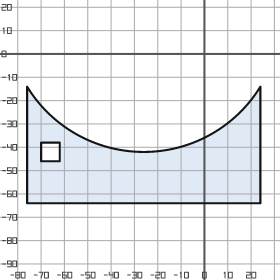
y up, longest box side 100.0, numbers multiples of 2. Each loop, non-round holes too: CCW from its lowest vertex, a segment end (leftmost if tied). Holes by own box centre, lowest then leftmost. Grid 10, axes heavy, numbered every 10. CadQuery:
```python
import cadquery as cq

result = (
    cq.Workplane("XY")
    .moveTo(-76.0, -64.0)
    .lineTo(24.0, -64.0)
    .lineTo(24.0, -14.0)
    .threePointArc((-26.0, -42.0), (-76.0, -14.0))
    .close()
    .moveTo(-70.0, -46.0)
    .lineTo(-62.0, -46.0)
    .lineTo(-62.0, -38.0)
    .lineTo(-70.0, -38.0)
    .close()
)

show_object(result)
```